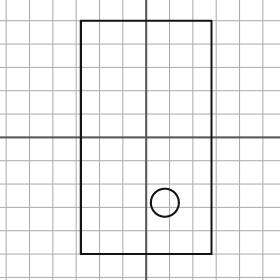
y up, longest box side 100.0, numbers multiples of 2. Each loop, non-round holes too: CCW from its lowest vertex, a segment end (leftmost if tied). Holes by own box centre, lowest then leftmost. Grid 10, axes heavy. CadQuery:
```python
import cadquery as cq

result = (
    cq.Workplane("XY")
    .moveTo(-28.0, -50.0)
    .lineTo(28.0, -50.0)
    .lineTo(28.0, 50.0)
    .lineTo(-28.0, 50.0)
    .close()
    .moveTo(8.0, -28.0)
    .circle(6.0)
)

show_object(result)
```